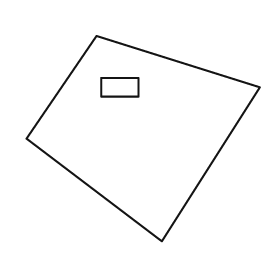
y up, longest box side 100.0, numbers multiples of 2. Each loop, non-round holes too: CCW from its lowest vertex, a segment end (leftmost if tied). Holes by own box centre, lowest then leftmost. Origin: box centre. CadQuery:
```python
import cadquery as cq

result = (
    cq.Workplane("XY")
    .moveTo(8.0, -44.0)
    .lineTo(50.0, 22.0)
    .lineTo(-20.0, 44.0)
    .lineTo(-50.0, 0.0)
    .close()
    .moveTo(-18.0, 18.0)
    .lineTo(-2.0, 18.0)
    .lineTo(-2.0, 26.0)
    .lineTo(-18.0, 26.0)
    .close()
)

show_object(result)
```